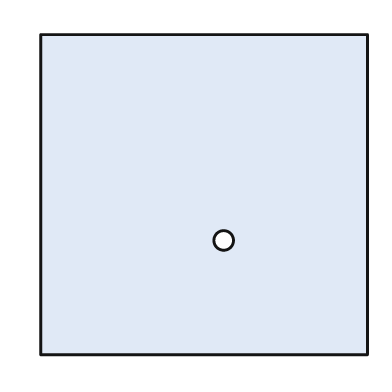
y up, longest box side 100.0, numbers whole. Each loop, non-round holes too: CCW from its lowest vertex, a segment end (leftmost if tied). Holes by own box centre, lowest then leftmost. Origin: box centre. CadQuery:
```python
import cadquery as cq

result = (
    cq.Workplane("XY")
    .moveTo(-50.0, -49.0)
    .lineTo(50.0, -49.0)
    .lineTo(50.0, 49.0)
    .lineTo(-50.0, 49.0)
    .close()
    .moveTo(6.0, -14.0)
    .circle(3.0)
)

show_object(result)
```